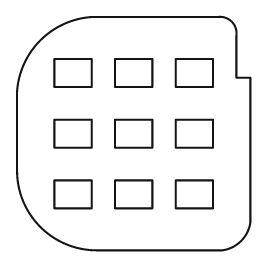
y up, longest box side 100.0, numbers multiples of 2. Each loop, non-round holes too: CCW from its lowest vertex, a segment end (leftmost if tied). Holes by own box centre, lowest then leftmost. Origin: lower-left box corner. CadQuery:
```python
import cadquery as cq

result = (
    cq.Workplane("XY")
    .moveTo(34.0, 0.0)
    .lineTo(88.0, 0.0)
    .threePointArc((96.0, 4.0), (100.0, 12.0))
    .lineTo(100.0, 74.0)
    .lineTo(94.0, 74.0)
    .lineTo(94.0, 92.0)
    .threePointArc((92.0, 98.0), (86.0, 100.0))
    .lineTo(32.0, 100.0)
    .threePointArc((10.0, 90.0), (0.0, 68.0))
    .lineTo(0.0, 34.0)
    .threePointArc((10.0, 10.0), (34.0, 0.0))
    .close()
    .moveTo(16.0, 18.0)
    .lineTo(32.0, 18.0)
    .lineTo(32.0, 30.0)
    .lineTo(16.0, 30.0)
    .close()
    .moveTo(42.0, 18.0)
    .lineTo(58.0, 18.0)
    .lineTo(58.0, 30.0)
    .lineTo(42.0, 30.0)
    .close()
    .moveTo(68.0, 18.0)
    .lineTo(84.0, 18.0)
    .lineTo(84.0, 30.0)
    .lineTo(68.0, 30.0)
    .close()
    .moveTo(16.0, 44.0)
    .lineTo(32.0, 44.0)
    .lineTo(32.0, 56.0)
    .lineTo(16.0, 56.0)
    .close()
    .moveTo(42.0, 44.0)
    .lineTo(58.0, 44.0)
    .lineTo(58.0, 56.0)
    .lineTo(42.0, 56.0)
    .close()
    .moveTo(68.0, 44.0)
    .lineTo(84.0, 44.0)
    .lineTo(84.0, 56.0)
    .lineTo(68.0, 56.0)
    .close()
    .moveTo(16.0, 70.0)
    .lineTo(32.0, 70.0)
    .lineTo(32.0, 82.0)
    .lineTo(16.0, 82.0)
    .close()
    .moveTo(42.0, 70.0)
    .lineTo(58.0, 70.0)
    .lineTo(58.0, 82.0)
    .lineTo(42.0, 82.0)
    .close()
    .moveTo(68.0, 70.0)
    .lineTo(84.0, 70.0)
    .lineTo(84.0, 82.0)
    .lineTo(68.0, 82.0)
    .close()
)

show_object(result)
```